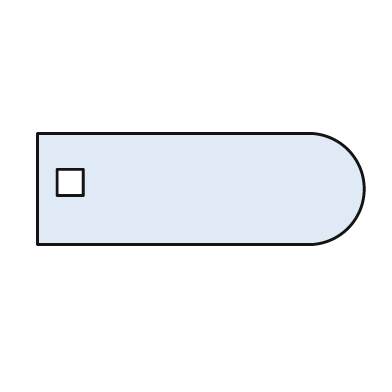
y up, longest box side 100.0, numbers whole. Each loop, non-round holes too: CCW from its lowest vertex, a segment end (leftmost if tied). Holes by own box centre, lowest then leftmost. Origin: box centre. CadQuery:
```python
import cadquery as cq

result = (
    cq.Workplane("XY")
    .moveTo(-50.0, -17.0)
    .lineTo(34.0, -17.0)
    .threePointArc((50.0, 0.0), (34.0, 17.0))
    .lineTo(-50.0, 17.0)
    .close()
    .moveTo(-44.0, -2.0)
    .lineTo(-36.0, -2.0)
    .lineTo(-36.0, 6.0)
    .lineTo(-44.0, 6.0)
    .close()
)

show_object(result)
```